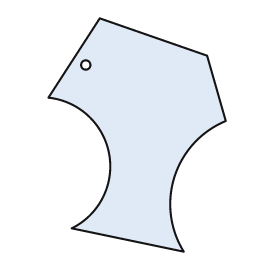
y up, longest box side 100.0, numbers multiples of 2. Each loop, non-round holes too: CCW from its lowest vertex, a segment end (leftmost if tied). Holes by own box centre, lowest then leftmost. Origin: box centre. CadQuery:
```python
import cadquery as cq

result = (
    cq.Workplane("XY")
    .moveTo(20.0, -50.0)
    .threePointArc((16.0, -18.0), (38.0, 6.0))
    .lineTo(30.0, 34.0)
    .lineTo(-16.0, 50.0)
    .lineTo(-38.0, 16.0)
    .threePointArc((-12.0, -8.0), (-28.0, -40.0))
    .close()
    .moveTo(-22.0, 30.0)
    .circle(2.0)
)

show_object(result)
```